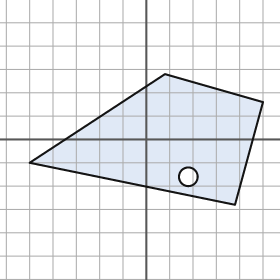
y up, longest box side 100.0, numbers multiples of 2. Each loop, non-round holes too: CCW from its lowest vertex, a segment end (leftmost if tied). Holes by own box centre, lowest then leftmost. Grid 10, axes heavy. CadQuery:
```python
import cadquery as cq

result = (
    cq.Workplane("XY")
    .moveTo(38.0, -28.0)
    .lineTo(50.0, 16.0)
    .lineTo(8.0, 28.0)
    .lineTo(-50.0, -10.0)
    .close()
    .moveTo(18.0, -16.0)
    .circle(4.0)
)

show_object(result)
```